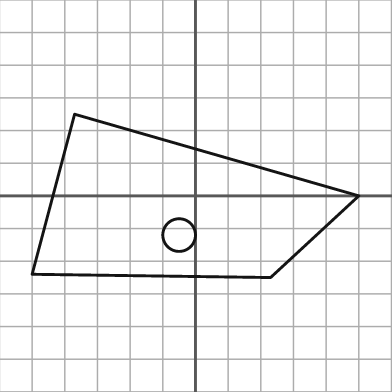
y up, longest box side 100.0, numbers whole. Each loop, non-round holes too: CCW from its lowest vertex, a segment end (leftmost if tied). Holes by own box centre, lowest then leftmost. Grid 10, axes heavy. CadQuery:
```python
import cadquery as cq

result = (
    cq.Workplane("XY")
    .moveTo(23.0, -25.0)
    .lineTo(50.0, 0.0)
    .lineTo(-37.0, 25.0)
    .lineTo(-50.0, -24.0)
    .close()
    .moveTo(-5.0, -12.0)
    .circle(5.0)
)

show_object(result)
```